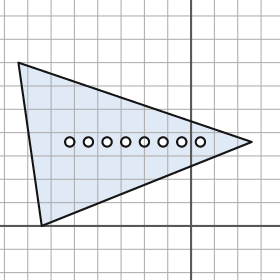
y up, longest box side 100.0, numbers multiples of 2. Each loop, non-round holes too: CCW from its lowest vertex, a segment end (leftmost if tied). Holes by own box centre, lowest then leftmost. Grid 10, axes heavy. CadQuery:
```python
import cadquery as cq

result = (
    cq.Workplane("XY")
    .moveTo(-64.0, 0.0)
    .lineTo(26.0, 36.0)
    .lineTo(-74.0, 70.0)
    .close()
    .moveTo(-52.0, 36.0)
    .circle(2.0)
    .moveTo(-44.0, 36.0)
    .circle(2.0)
    .moveTo(-36.0, 36.0)
    .circle(2.0)
    .moveTo(-28.0, 36.0)
    .circle(2.0)
    .moveTo(-20.0, 36.0)
    .circle(2.0)
    .moveTo(-12.0, 36.0)
    .circle(2.0)
    .moveTo(-4.0, 36.0)
    .circle(2.0)
    .moveTo(4.0, 36.0)
    .circle(2.0)
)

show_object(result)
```